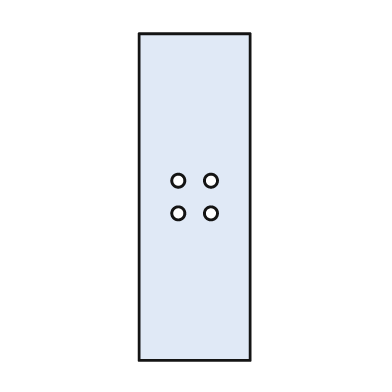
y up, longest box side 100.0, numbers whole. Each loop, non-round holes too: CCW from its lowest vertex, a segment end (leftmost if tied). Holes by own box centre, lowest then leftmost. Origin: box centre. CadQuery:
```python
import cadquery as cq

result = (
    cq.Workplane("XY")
    .moveTo(-17.0, -50.0)
    .lineTo(17.0, -50.0)
    .lineTo(17.0, 50.0)
    .lineTo(-17.0, 50.0)
    .close()
    .moveTo(-5.0, -5.0)
    .circle(2.0)
    .moveTo(5.0, -5.0)
    .circle(2.0)
    .moveTo(-5.0, 5.0)
    .circle(2.0)
    .moveTo(5.0, 5.0)
    .circle(2.0)
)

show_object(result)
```